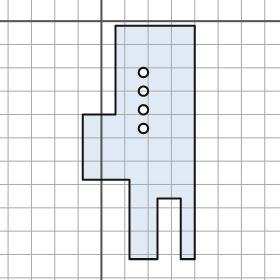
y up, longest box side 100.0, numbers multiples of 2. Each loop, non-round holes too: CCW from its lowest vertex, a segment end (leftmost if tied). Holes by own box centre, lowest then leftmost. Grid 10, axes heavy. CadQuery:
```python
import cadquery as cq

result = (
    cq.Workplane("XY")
    .moveTo(12.0, -102.0)
    .lineTo(24.0, -102.0)
    .lineTo(24.0, -76.0)
    .lineTo(34.0, -76.0)
    .lineTo(34.0, -102.0)
    .lineTo(40.0, -102.0)
    .lineTo(40.0, -2.0)
    .lineTo(6.0, -2.0)
    .lineTo(6.0, -40.0)
    .lineTo(-8.0, -40.0)
    .lineTo(-8.0, -68.0)
    .lineTo(12.0, -68.0)
    .close()
    .moveTo(18.0, -46.0)
    .circle(2.0)
    .moveTo(18.0, -38.0)
    .circle(2.0)
    .moveTo(18.0, -30.0)
    .circle(2.0)
    .moveTo(18.0, -22.0)
    .circle(2.0)
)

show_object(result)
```